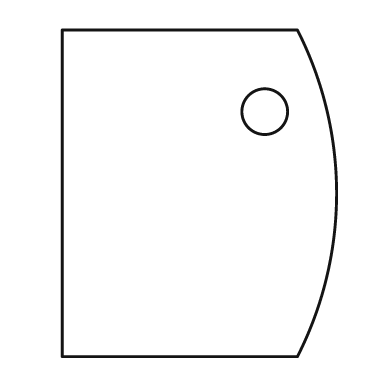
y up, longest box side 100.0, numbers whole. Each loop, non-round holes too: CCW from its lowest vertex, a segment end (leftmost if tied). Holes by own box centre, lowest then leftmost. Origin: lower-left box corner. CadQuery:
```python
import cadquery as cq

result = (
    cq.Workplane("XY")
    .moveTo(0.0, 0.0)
    .lineTo(72.0, 0.0)
    .threePointArc((84.0, 50.0), (72.0, 100.0))
    .lineTo(0.0, 100.0)
    .close()
    .moveTo(62.0, 75.0)
    .circle(7.0)
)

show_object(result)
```